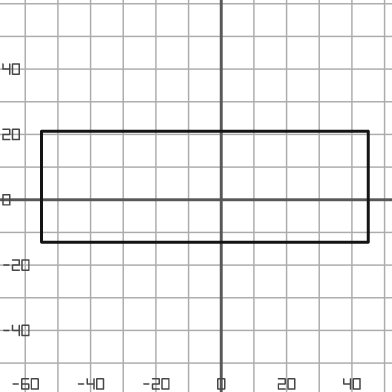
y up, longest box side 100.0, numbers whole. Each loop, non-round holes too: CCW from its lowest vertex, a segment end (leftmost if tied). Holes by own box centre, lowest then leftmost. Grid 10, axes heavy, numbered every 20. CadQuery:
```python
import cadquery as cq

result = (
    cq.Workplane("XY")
    .moveTo(-55.0, -13.0)
    .lineTo(45.0, -13.0)
    .lineTo(45.0, 21.0)
    .lineTo(-55.0, 21.0)
    .close()
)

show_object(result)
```